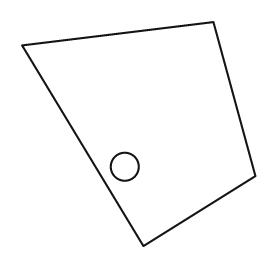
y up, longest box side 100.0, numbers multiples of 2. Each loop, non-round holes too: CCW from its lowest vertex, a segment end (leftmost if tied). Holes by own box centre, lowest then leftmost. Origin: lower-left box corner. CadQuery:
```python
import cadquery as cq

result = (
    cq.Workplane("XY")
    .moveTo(52.0, 0.0)
    .lineTo(100.0, 30.0)
    .lineTo(82.0, 96.0)
    .lineTo(0.0, 86.0)
    .close()
    .moveTo(44.0, 34.0)
    .circle(6.0)
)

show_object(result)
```